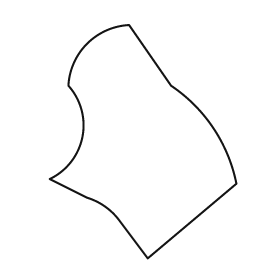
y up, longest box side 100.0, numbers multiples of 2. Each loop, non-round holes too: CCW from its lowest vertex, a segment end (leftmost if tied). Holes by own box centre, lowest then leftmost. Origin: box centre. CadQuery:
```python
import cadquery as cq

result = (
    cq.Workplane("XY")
    .moveTo(2.0, -50.0)
    .lineTo(40.0, -18.0)
    .threePointArc((30.0, 6.0), (12.0, 24.0))
    .lineTo(-6.0, 50.0)
    .threePointArc((-24.0, 42.0), (-32.0, 24.0))
    .threePointArc((-26.0, 2.0), (-40.0, -16.0))
    .lineTo(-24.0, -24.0)
    .threePointArc((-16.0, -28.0), (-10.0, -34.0))
    .close()
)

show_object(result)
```